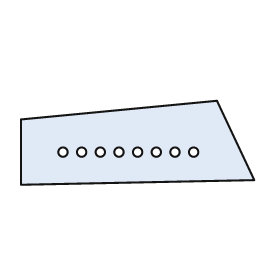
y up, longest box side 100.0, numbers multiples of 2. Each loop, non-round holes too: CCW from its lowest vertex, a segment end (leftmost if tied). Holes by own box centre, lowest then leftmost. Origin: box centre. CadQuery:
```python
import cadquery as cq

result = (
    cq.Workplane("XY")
    .moveTo(-50.0, -18.0)
    .lineTo(50.0, -16.0)
    .lineTo(34.0, 18.0)
    .lineTo(-50.0, 10.0)
    .close()
    .moveTo(-32.0, -4.0)
    .circle(2.0)
    .moveTo(-24.0, -4.0)
    .circle(2.0)
    .moveTo(-16.0, -4.0)
    .circle(2.0)
    .moveTo(-8.0, -4.0)
    .circle(2.0)
    .moveTo(0.0, -4.0)
    .circle(2.0)
    .moveTo(8.0, -4.0)
    .circle(2.0)
    .moveTo(16.0, -4.0)
    .circle(2.0)
    .moveTo(24.0, -4.0)
    .circle(2.0)
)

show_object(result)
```